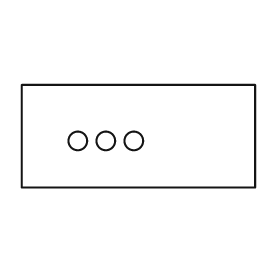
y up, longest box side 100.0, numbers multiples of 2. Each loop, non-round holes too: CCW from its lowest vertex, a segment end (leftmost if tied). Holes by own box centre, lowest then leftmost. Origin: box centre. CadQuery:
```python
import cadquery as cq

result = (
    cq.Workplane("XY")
    .moveTo(-50.0, -22.0)
    .lineTo(50.0, -22.0)
    .lineTo(50.0, 22.0)
    .lineTo(-50.0, 22.0)
    .close()
    .moveTo(-26.0, -2.0)
    .circle(4.0)
    .moveTo(-14.0, -2.0)
    .circle(4.0)
    .moveTo(-2.0, -2.0)
    .circle(4.0)
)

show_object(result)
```